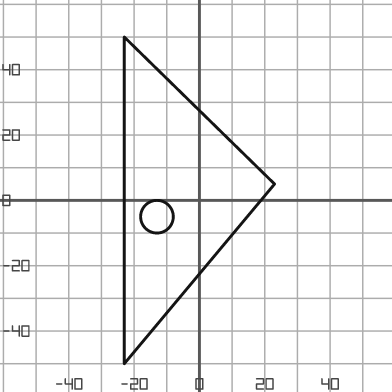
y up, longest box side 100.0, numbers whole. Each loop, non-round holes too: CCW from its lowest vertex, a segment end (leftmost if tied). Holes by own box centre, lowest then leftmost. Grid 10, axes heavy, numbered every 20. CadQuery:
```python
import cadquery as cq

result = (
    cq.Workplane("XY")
    .moveTo(-23.0, -50.0)
    .lineTo(23.0, 5.0)
    .lineTo(-23.0, 50.0)
    .close()
    .moveTo(-13.0, -5.0)
    .circle(5.0)
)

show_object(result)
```